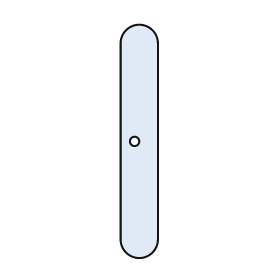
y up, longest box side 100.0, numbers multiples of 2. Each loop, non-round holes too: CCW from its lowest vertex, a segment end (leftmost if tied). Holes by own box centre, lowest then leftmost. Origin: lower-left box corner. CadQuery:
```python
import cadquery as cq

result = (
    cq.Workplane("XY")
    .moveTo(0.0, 8.0)
    .threePointArc((8.0, 0.0), (16.0, 8.0))
    .lineTo(16.0, 92.0)
    .threePointArc((8.0, 100.0), (0.0, 92.0))
    .close()
    .moveTo(6.0, 50.0)
    .circle(2.0)
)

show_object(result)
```